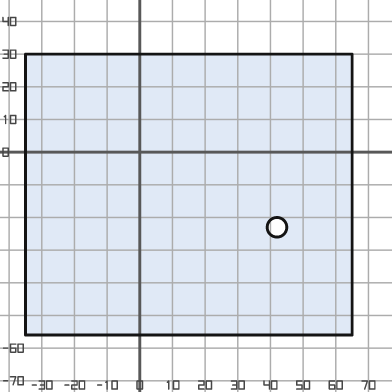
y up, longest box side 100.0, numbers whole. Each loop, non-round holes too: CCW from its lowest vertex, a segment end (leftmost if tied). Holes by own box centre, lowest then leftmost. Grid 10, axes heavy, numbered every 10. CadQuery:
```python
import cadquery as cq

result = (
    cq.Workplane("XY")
    .moveTo(-35.0, -56.0)
    .lineTo(65.0, -56.0)
    .lineTo(65.0, 30.0)
    .lineTo(-35.0, 30.0)
    .close()
    .moveTo(42.0, -23.0)
    .circle(3.0)
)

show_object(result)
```